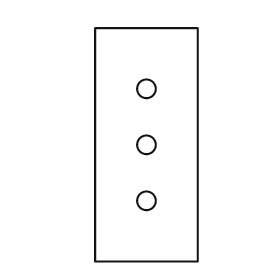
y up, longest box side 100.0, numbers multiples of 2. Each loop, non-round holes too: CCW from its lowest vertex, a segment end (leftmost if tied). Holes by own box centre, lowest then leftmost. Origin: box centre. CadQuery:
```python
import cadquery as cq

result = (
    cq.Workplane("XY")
    .moveTo(-22.0, -50.0)
    .lineTo(22.0, -50.0)
    .lineTo(22.0, 50.0)
    .lineTo(-22.0, 50.0)
    .close()
    .moveTo(0.0, -24.0)
    .circle(4.0)
    .moveTo(0.0, 0.0)
    .circle(4.0)
    .moveTo(0.0, 24.0)
    .circle(4.0)
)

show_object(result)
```